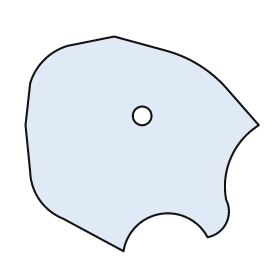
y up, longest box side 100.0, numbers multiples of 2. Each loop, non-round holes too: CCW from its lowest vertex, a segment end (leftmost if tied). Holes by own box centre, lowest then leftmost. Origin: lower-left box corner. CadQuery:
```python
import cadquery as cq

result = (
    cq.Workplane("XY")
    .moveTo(42.0, 0.0)
    .threePointArc((58.0, 16.0), (78.0, 6.0))
    .threePointArc((86.0, 12.0), (86.0, 22.0))
    .threePointArc((88.0, 40.0), (100.0, 54.0))
    .lineTo(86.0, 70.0)
    .threePointArc((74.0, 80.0), (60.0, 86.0))
    .lineTo(38.0, 92.0)
    .lineTo(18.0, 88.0)
    .threePointArc((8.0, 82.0), (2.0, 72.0))
    .lineTo(0.0, 54.0)
    .lineTo(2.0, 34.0)
    .threePointArc((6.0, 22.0), (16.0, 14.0))
    .close()
    .moveTo(50.0, 58.0)
    .circle(4.0)
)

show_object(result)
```